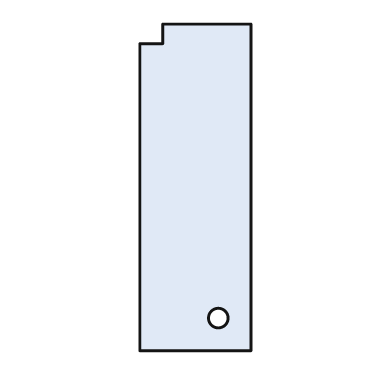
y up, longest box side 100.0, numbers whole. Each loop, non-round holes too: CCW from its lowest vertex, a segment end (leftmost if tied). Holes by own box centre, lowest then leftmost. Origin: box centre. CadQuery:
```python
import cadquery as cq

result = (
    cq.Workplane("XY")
    .moveTo(-17.0, -50.0)
    .lineTo(17.0, -50.0)
    .lineTo(17.0, 50.0)
    .lineTo(-10.0, 50.0)
    .lineTo(-10.0, 44.0)
    .lineTo(-17.0, 44.0)
    .close()
    .moveTo(7.0, -40.0)
    .circle(3.0)
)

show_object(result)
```